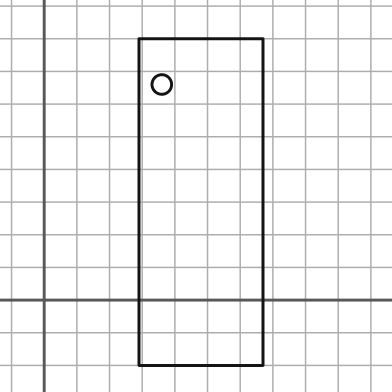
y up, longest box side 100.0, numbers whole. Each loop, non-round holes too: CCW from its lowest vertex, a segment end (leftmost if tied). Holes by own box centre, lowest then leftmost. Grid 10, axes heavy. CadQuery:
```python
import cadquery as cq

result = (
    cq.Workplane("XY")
    .moveTo(29.0, -20.0)
    .lineTo(67.0, -20.0)
    .lineTo(67.0, 80.0)
    .lineTo(29.0, 80.0)
    .close()
    .moveTo(36.0, 66.0)
    .circle(3.0)
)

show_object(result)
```